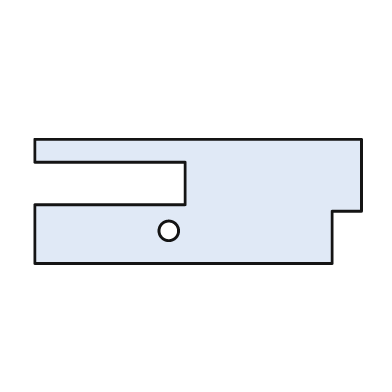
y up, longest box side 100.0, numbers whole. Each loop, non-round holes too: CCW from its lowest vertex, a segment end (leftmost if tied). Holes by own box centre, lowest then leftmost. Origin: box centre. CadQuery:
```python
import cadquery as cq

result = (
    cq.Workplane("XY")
    .moveTo(-50.0, -19.0)
    .lineTo(41.0, -19.0)
    .lineTo(41.0, -3.0)
    .lineTo(50.0, -3.0)
    .lineTo(50.0, 19.0)
    .lineTo(-50.0, 19.0)
    .lineTo(-50.0, 12.0)
    .lineTo(-4.0, 12.0)
    .lineTo(-4.0, -1.0)
    .lineTo(-50.0, -1.0)
    .close()
    .moveTo(-9.0, -9.0)
    .circle(3.0)
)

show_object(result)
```